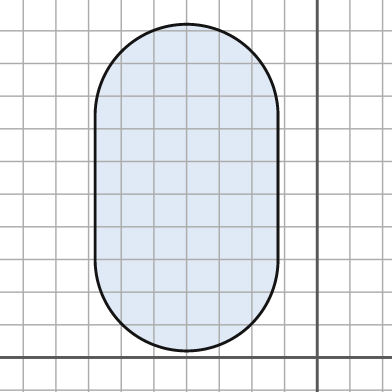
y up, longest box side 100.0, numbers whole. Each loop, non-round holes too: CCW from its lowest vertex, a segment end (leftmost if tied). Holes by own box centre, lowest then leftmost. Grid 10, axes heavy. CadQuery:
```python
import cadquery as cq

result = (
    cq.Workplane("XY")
    .moveTo(-68.0, 30.0)
    .threePointArc((-40.0, 2.0), (-12.0, 30.0))
    .lineTo(-12.0, 74.0)
    .threePointArc((-40.0, 102.0), (-68.0, 74.0))
    .close()
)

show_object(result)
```